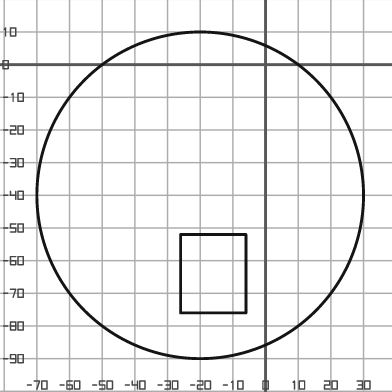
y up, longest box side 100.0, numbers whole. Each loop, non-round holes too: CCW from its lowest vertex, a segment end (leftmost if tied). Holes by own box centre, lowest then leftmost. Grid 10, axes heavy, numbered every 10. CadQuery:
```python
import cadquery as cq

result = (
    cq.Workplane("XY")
    .moveTo(-20.0, -40.0)
    .circle(50.0)
    .moveTo(-26.0, -76.0)
    .lineTo(-6.0, -76.0)
    .lineTo(-6.0, -52.0)
    .lineTo(-26.0, -52.0)
    .close()
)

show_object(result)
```